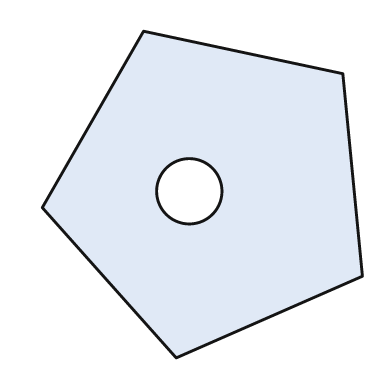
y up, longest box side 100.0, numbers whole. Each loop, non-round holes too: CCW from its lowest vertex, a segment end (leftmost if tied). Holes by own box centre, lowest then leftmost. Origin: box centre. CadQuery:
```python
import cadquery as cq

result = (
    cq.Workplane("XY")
    .moveTo(-8.0, -50.0)
    .lineTo(49.0, -25.0)
    .lineTo(43.0, 37.0)
    .lineTo(-18.0, 50.0)
    .lineTo(-49.0, -4.0)
    .close()
    .moveTo(-4.0, 1.0)
    .circle(10.0)
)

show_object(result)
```